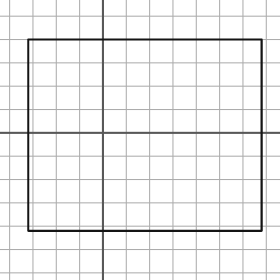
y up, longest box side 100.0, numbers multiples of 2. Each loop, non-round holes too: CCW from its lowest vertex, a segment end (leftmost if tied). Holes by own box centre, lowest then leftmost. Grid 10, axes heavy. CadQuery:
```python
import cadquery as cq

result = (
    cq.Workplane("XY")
    .moveTo(-32.0, -42.0)
    .lineTo(68.0, -42.0)
    .lineTo(68.0, 40.0)
    .lineTo(-32.0, 40.0)
    .close()
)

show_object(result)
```